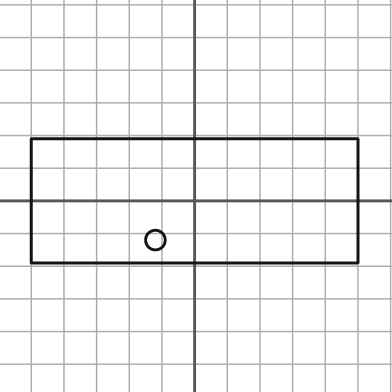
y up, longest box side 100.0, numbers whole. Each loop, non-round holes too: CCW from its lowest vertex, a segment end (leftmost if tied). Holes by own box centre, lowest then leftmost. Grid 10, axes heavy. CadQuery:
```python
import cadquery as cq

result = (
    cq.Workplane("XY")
    .moveTo(-50.0, -19.0)
    .lineTo(50.0, -19.0)
    .lineTo(50.0, 19.0)
    .lineTo(-50.0, 19.0)
    .close()
    .moveTo(-12.0, -12.0)
    .circle(3.0)
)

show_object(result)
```